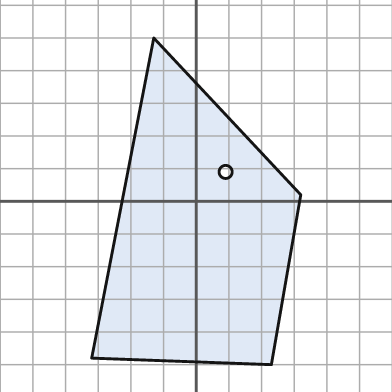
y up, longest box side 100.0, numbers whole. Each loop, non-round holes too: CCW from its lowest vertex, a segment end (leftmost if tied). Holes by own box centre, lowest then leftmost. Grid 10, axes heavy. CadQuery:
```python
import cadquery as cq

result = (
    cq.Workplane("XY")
    .moveTo(23.0, -50.0)
    .lineTo(32.0, 2.0)
    .lineTo(-13.0, 50.0)
    .lineTo(-32.0, -48.0)
    .close()
    .moveTo(9.0, 9.0)
    .circle(2.0)
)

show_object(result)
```